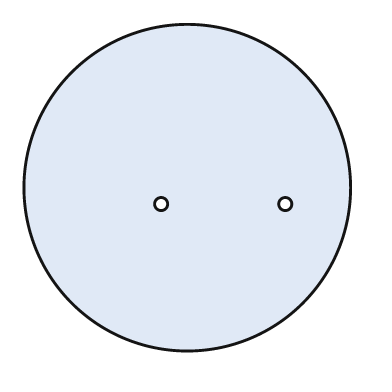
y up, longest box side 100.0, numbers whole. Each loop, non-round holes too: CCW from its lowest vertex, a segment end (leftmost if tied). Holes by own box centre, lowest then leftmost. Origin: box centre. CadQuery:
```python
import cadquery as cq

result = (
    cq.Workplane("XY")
    .moveTo(0.0, 0.0)
    .circle(50.0)
    .moveTo(-8.0, -5.0)
    .circle(2.0)
    .moveTo(30.0, -5.0)
    .circle(2.0)
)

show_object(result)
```